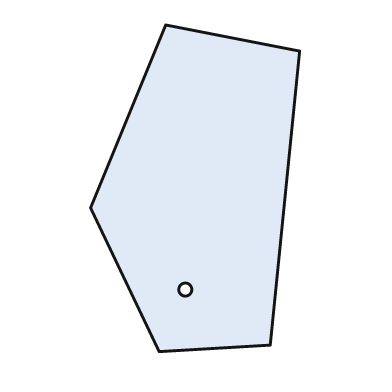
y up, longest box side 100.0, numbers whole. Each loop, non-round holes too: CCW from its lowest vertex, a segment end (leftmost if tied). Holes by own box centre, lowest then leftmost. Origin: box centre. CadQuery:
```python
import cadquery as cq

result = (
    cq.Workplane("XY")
    .moveTo(-11.0, -50.0)
    .lineTo(23.0, -48.0)
    .lineTo(32.0, 42.0)
    .lineTo(-9.0, 50.0)
    .lineTo(-32.0, -6.0)
    .close()
    .moveTo(-3.0, -31.0)
    .circle(2.0)
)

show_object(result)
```